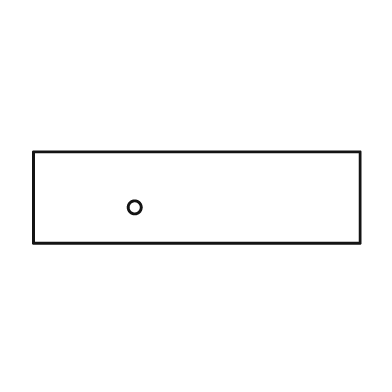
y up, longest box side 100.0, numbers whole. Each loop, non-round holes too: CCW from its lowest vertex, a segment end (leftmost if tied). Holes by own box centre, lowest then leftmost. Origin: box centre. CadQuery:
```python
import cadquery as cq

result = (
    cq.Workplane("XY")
    .moveTo(-50.0, -14.0)
    .lineTo(50.0, -14.0)
    .lineTo(50.0, 14.0)
    .lineTo(-50.0, 14.0)
    .close()
    .moveTo(-19.0, -3.0)
    .circle(2.0)
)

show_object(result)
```